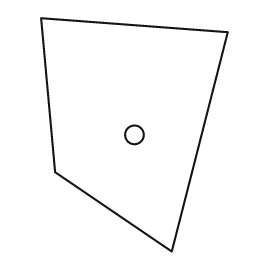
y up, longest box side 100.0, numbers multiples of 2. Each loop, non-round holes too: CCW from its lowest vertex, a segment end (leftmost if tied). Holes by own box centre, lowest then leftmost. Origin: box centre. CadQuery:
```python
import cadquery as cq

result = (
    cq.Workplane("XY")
    .moveTo(16.0, -50.0)
    .lineTo(40.0, 44.0)
    .lineTo(-40.0, 50.0)
    .lineTo(-34.0, -16.0)
    .close()
    .moveTo(0.0, 0.0)
    .circle(4.0)
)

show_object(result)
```